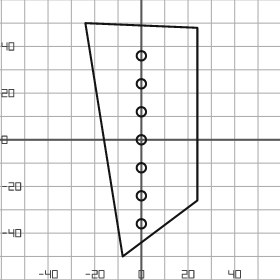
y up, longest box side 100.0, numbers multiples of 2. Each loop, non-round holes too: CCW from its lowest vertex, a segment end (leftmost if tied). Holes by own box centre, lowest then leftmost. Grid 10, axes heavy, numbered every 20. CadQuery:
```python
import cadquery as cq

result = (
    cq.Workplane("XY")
    .moveTo(-8.0, -50.0)
    .lineTo(24.0, -26.0)
    .lineTo(24.0, 48.0)
    .lineTo(-24.0, 50.0)
    .close()
    .moveTo(0.0, -36.0)
    .circle(2.0)
    .moveTo(0.0, -24.0)
    .circle(2.0)
    .moveTo(0.0, -12.0)
    .circle(2.0)
    .moveTo(0.0, 0.0)
    .circle(2.0)
    .moveTo(0.0, 12.0)
    .circle(2.0)
    .moveTo(0.0, 24.0)
    .circle(2.0)
    .moveTo(0.0, 36.0)
    .circle(2.0)
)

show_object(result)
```